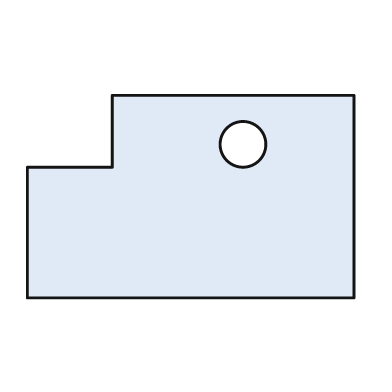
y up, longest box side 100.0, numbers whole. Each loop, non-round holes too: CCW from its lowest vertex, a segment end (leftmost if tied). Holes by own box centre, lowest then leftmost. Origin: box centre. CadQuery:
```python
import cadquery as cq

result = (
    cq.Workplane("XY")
    .moveTo(-50.0, -31.0)
    .lineTo(50.0, -31.0)
    .lineTo(50.0, 31.0)
    .lineTo(-24.0, 31.0)
    .lineTo(-24.0, 9.0)
    .lineTo(-50.0, 9.0)
    .close()
    .moveTo(16.0, 16.0)
    .circle(7.0)
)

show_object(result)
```